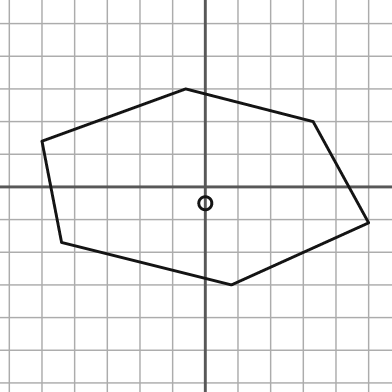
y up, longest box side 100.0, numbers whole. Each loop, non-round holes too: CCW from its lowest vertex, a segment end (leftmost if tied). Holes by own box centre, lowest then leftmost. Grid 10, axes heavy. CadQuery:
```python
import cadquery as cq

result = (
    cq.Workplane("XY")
    .moveTo(8.0, -30.0)
    .lineTo(50.0, -11.0)
    .lineTo(33.0, 20.0)
    .lineTo(-6.0, 30.0)
    .lineTo(-50.0, 14.0)
    .lineTo(-44.0, -17.0)
    .close()
    .moveTo(0.0, -5.0)
    .circle(2.0)
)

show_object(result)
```